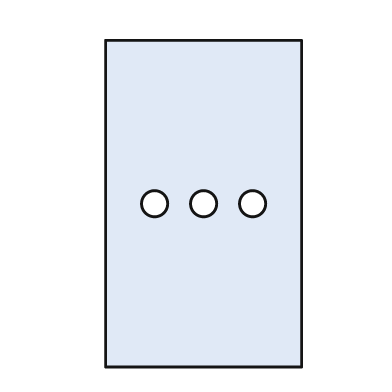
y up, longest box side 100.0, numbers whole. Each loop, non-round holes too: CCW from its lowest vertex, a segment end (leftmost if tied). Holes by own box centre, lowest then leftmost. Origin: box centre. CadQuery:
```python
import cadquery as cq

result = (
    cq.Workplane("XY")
    .moveTo(-30.0, -50.0)
    .lineTo(30.0, -50.0)
    .lineTo(30.0, 50.0)
    .lineTo(-30.0, 50.0)
    .close()
    .moveTo(-15.0, 0.0)
    .circle(4.0)
    .moveTo(0.0, 0.0)
    .circle(4.0)
    .moveTo(15.0, 0.0)
    .circle(4.0)
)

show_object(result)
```